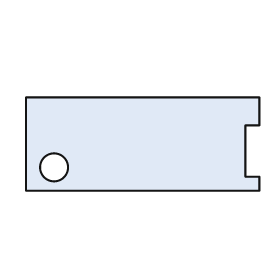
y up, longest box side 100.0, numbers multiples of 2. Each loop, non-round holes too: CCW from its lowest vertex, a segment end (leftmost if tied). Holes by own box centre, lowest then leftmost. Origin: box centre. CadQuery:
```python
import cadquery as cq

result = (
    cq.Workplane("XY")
    .moveTo(-50.0, -20.0)
    .lineTo(50.0, -20.0)
    .lineTo(50.0, -14.0)
    .lineTo(44.0, -14.0)
    .lineTo(44.0, 8.0)
    .lineTo(50.0, 8.0)
    .lineTo(50.0, 20.0)
    .lineTo(-50.0, 20.0)
    .close()
    .moveTo(-38.0, -10.0)
    .circle(6.0)
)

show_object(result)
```